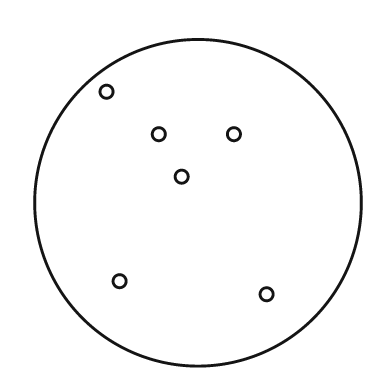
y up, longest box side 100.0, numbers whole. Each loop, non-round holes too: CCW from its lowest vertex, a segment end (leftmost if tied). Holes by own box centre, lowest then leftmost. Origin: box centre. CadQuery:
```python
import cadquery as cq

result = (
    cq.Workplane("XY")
    .moveTo(0.0, 0.0)
    .circle(50.0)
    .moveTo(21.0, -28.0)
    .circle(2.0)
    .moveTo(-24.0, -24.0)
    .circle(2.0)
    .moveTo(-5.0, 8.0)
    .circle(2.0)
    .moveTo(-12.0, 21.0)
    .circle(2.0)
    .moveTo(11.0, 21.0)
    .circle(2.0)
    .moveTo(-28.0, 34.0)
    .circle(2.0)
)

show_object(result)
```